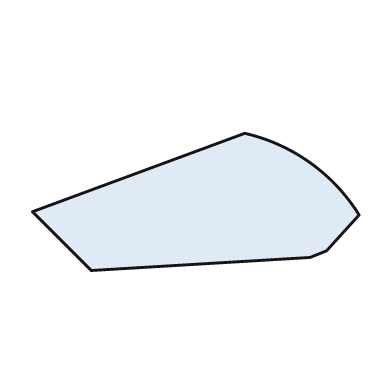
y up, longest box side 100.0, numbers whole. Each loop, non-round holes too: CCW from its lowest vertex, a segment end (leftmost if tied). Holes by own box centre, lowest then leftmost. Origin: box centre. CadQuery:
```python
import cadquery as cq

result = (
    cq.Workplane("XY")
    .moveTo(-32.0, -21.0)
    .lineTo(35.0, -17.0)
    .lineTo(40.0, -15.0)
    .lineTo(50.0, -4.0)
    .threePointArc((35.0, 12.0), (15.0, 21.0))
    .lineTo(-50.0, -3.0)
    .close()
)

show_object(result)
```